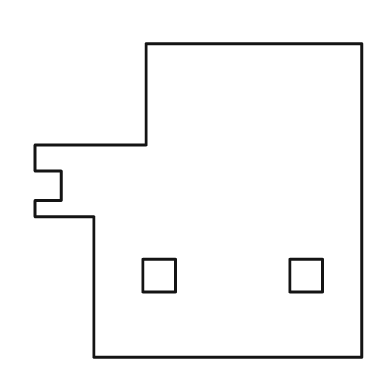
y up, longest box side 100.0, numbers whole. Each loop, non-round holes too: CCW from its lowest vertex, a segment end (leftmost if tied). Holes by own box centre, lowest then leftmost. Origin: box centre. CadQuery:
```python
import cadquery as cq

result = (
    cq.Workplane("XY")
    .moveTo(-32.0, -48.0)
    .lineTo(50.0, -48.0)
    .lineTo(50.0, 48.0)
    .lineTo(-16.0, 48.0)
    .lineTo(-16.0, 17.0)
    .lineTo(-50.0, 17.0)
    .lineTo(-50.0, 9.0)
    .lineTo(-42.0, 9.0)
    .lineTo(-42.0, 0.0)
    .lineTo(-50.0, 0.0)
    .lineTo(-50.0, -5.0)
    .lineTo(-32.0, -5.0)
    .close()
    .moveTo(-17.0, -28.0)
    .lineTo(-7.0, -28.0)
    .lineTo(-7.0, -18.0)
    .lineTo(-17.0, -18.0)
    .close()
    .moveTo(28.0, -28.0)
    .lineTo(38.0, -28.0)
    .lineTo(38.0, -18.0)
    .lineTo(28.0, -18.0)
    .close()
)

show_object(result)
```